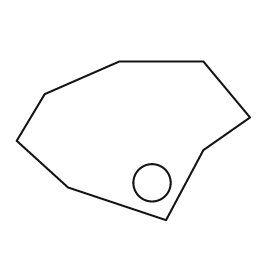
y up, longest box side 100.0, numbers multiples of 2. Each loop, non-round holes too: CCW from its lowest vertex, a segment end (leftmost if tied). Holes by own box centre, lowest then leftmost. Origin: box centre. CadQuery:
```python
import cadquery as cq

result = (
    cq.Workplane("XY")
    .moveTo(14.0, -34.0)
    .lineTo(30.0, -4.0)
    .lineTo(50.0, 10.0)
    .lineTo(30.0, 34.0)
    .lineTo(-6.0, 34.0)
    .lineTo(-38.0, 20.0)
    .lineTo(-50.0, 0.0)
    .lineTo(-28.0, -20.0)
    .close()
    .moveTo(8.0, -18.0)
    .circle(8.0)
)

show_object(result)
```